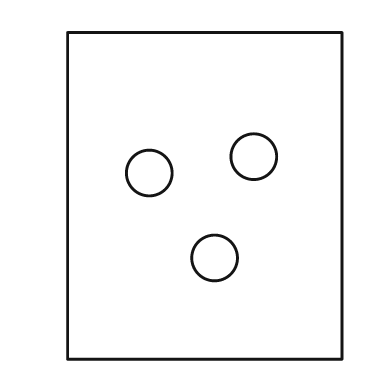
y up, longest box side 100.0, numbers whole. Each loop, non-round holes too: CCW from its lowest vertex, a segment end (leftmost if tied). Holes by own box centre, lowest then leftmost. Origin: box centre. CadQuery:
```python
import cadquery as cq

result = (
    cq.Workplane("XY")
    .moveTo(-42.0, -50.0)
    .lineTo(42.0, -50.0)
    .lineTo(42.0, 50.0)
    .lineTo(-42.0, 50.0)
    .close()
    .moveTo(3.0, -19.0)
    .circle(7.0)
    .moveTo(-17.0, 7.0)
    .circle(7.0)
    .moveTo(15.0, 12.0)
    .circle(7.0)
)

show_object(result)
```